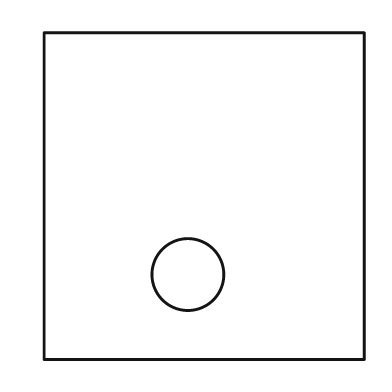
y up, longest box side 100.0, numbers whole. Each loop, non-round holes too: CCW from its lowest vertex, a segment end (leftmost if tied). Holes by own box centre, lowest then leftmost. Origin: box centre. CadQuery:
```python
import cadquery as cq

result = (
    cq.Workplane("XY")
    .moveTo(-49.0, -50.0)
    .lineTo(49.0, -50.0)
    .lineTo(49.0, 50.0)
    .lineTo(-49.0, 50.0)
    .close()
    .moveTo(-5.0, -24.0)
    .circle(11.0)
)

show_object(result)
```